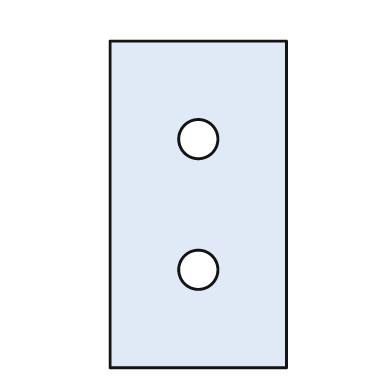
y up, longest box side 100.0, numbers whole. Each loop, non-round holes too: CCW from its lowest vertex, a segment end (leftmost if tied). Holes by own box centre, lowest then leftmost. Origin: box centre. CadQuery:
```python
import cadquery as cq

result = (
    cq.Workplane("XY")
    .moveTo(-27.0, -50.0)
    .lineTo(27.0, -50.0)
    .lineTo(27.0, 50.0)
    .lineTo(-27.0, 50.0)
    .close()
    .moveTo(0.0, -20.0)
    .circle(6.0)
    .moveTo(0.0, 20.0)
    .circle(6.0)
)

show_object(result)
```